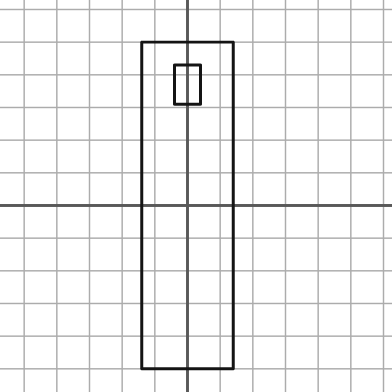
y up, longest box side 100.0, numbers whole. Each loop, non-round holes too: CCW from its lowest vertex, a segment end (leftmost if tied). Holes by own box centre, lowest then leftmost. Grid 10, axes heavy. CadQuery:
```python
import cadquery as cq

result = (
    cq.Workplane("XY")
    .moveTo(-14.0, -50.0)
    .lineTo(14.0, -50.0)
    .lineTo(14.0, 50.0)
    .lineTo(-14.0, 50.0)
    .close()
    .moveTo(-4.0, 31.0)
    .lineTo(4.0, 31.0)
    .lineTo(4.0, 43.0)
    .lineTo(-4.0, 43.0)
    .close()
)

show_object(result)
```